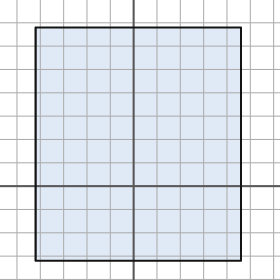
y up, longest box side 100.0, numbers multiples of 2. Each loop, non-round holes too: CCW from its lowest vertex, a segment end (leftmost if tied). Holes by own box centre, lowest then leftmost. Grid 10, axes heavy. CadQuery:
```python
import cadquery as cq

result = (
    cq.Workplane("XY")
    .moveTo(-42.0, -32.0)
    .lineTo(46.0, -32.0)
    .lineTo(46.0, 68.0)
    .lineTo(-42.0, 68.0)
    .close()
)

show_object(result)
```